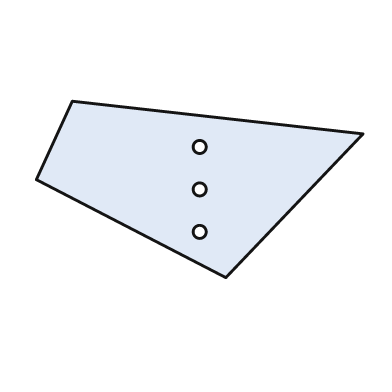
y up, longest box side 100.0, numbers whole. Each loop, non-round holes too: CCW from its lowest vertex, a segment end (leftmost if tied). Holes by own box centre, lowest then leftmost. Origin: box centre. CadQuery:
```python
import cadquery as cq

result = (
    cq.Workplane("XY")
    .moveTo(8.0, -27.0)
    .lineTo(50.0, 17.0)
    .lineTo(-39.0, 27.0)
    .lineTo(-50.0, 3.0)
    .close()
    .moveTo(0.0, -13.0)
    .circle(2.0)
    .moveTo(0.0, 0.0)
    .circle(2.0)
    .moveTo(0.0, 13.0)
    .circle(2.0)
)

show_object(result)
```